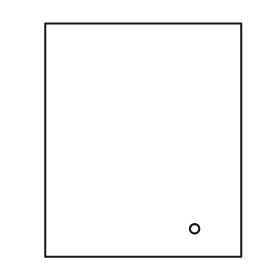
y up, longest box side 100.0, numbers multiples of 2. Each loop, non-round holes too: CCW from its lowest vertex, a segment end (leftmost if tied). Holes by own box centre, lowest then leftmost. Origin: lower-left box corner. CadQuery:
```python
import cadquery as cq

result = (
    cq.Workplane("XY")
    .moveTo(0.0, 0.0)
    .lineTo(84.0, 0.0)
    .lineTo(84.0, 100.0)
    .lineTo(0.0, 100.0)
    .close()
    .moveTo(64.0, 12.0)
    .circle(2.0)
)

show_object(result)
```